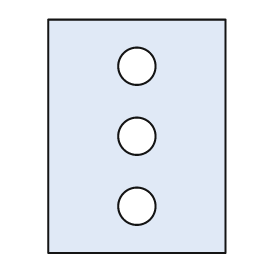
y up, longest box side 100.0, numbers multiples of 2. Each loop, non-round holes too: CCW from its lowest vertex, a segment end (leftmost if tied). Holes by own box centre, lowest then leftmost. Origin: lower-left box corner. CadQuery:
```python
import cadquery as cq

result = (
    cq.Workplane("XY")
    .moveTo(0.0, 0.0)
    .lineTo(76.0, 0.0)
    .lineTo(76.0, 100.0)
    .lineTo(0.0, 100.0)
    .close()
    .moveTo(38.0, 20.0)
    .circle(8.0)
    .moveTo(38.0, 50.0)
    .circle(8.0)
    .moveTo(38.0, 80.0)
    .circle(8.0)
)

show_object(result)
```